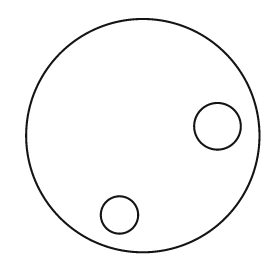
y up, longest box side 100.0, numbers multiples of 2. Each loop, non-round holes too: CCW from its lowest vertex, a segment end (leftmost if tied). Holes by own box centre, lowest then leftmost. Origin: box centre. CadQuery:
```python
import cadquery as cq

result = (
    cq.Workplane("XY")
    .moveTo(0.0, 0.0)
    .circle(50.0)
    .moveTo(-10.0, -34.0)
    .circle(8.0)
    .moveTo(32.0, 4.0)
    .circle(10.0)
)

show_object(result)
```